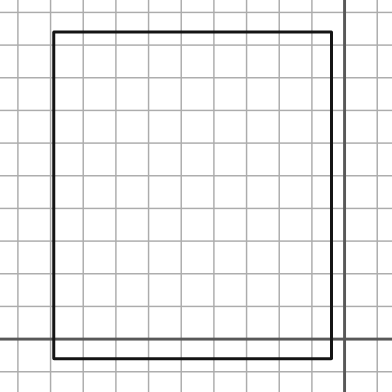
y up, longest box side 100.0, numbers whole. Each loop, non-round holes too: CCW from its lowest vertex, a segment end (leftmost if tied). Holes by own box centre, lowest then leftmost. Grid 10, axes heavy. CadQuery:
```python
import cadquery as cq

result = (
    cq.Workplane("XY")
    .moveTo(-89.0, -6.0)
    .lineTo(-4.0, -6.0)
    .lineTo(-4.0, 94.0)
    .lineTo(-89.0, 94.0)
    .close()
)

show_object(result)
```